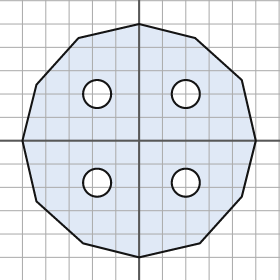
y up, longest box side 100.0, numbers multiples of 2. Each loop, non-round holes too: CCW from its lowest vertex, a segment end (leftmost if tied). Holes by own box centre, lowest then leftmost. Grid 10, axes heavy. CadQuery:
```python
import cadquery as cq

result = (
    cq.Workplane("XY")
    .moveTo(0.0, -50.0)
    .lineTo(26.0, -44.0)
    .lineTo(44.0, -24.0)
    .lineTo(50.0, 0.0)
    .lineTo(44.0, 26.0)
    .lineTo(24.0, 44.0)
    .lineTo(0.0, 50.0)
    .lineTo(-26.0, 44.0)
    .lineTo(-44.0, 24.0)
    .lineTo(-50.0, 0.0)
    .lineTo(-44.0, -26.0)
    .lineTo(-24.0, -44.0)
    .close()
    .moveTo(-18.0, -18.0)
    .circle(6.0)
    .moveTo(20.0, -18.0)
    .circle(6.0)
    .moveTo(-18.0, 20.0)
    .circle(6.0)
    .moveTo(20.0, 20.0)
    .circle(6.0)
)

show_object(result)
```